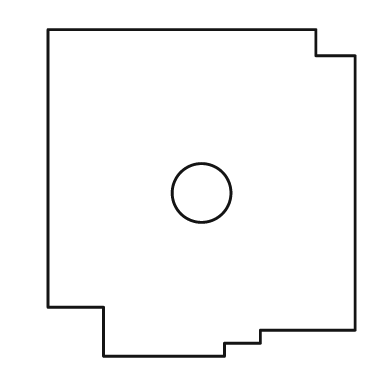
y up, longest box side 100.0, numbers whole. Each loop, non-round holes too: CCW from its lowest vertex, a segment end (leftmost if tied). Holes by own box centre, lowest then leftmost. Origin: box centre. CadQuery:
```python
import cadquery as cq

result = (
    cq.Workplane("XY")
    .moveTo(-30.0, -50.0)
    .lineTo(7.0, -50.0)
    .lineTo(7.0, -46.0)
    .lineTo(18.0, -46.0)
    .lineTo(18.0, -42.0)
    .lineTo(47.0, -42.0)
    .lineTo(47.0, 42.0)
    .lineTo(35.0, 42.0)
    .lineTo(35.0, 50.0)
    .lineTo(-47.0, 50.0)
    .lineTo(-47.0, -35.0)
    .lineTo(-30.0, -35.0)
    .close()
    .moveTo(0.0, 0.0)
    .circle(9.0)
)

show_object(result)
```